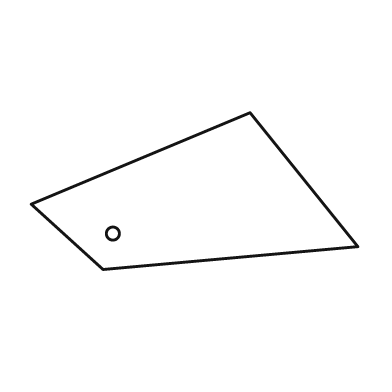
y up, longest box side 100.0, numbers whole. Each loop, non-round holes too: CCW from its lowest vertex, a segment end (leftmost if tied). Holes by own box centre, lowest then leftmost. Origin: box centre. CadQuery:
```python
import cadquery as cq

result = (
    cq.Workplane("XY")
    .moveTo(-28.0, -24.0)
    .lineTo(50.0, -17.0)
    .lineTo(17.0, 24.0)
    .lineTo(-50.0, -4.0)
    .close()
    .moveTo(-25.0, -13.0)
    .circle(2.0)
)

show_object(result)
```